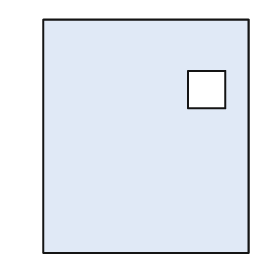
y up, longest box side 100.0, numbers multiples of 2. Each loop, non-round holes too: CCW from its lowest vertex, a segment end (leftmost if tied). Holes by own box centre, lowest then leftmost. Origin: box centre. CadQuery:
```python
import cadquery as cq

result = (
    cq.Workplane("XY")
    .moveTo(-44.0, -50.0)
    .lineTo(44.0, -50.0)
    .lineTo(44.0, 50.0)
    .lineTo(-44.0, 50.0)
    .close()
    .moveTo(18.0, 12.0)
    .lineTo(34.0, 12.0)
    .lineTo(34.0, 28.0)
    .lineTo(18.0, 28.0)
    .close()
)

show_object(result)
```